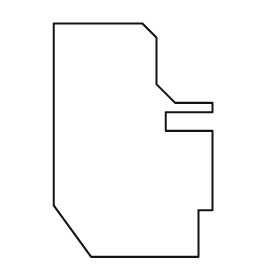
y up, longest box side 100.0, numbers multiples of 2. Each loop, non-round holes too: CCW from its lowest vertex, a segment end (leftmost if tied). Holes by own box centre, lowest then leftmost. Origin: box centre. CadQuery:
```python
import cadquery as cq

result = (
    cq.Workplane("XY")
    .moveTo(-18.0, -50.0)
    .lineTo(28.0, -50.0)
    .lineTo(28.0, -30.0)
    .lineTo(34.0, -30.0)
    .lineTo(34.0, 4.0)
    .lineTo(14.0, 4.0)
    .lineTo(14.0, 12.0)
    .lineTo(34.0, 12.0)
    .lineTo(34.0, 16.0)
    .lineTo(18.0, 16.0)
    .lineTo(10.0, 24.0)
    .lineTo(10.0, 44.0)
    .lineTo(4.0, 50.0)
    .lineTo(-34.0, 50.0)
    .lineTo(-34.0, -28.0)
    .close()
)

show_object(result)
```